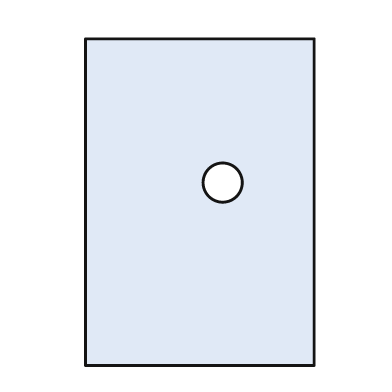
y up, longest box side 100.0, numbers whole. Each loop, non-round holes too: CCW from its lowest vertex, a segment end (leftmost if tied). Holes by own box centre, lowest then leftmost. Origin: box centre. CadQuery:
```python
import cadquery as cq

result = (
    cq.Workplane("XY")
    .moveTo(-35.0, -50.0)
    .lineTo(35.0, -50.0)
    .lineTo(35.0, 50.0)
    .lineTo(-35.0, 50.0)
    .close()
    .moveTo(7.0, 6.0)
    .circle(6.0)
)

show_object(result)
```